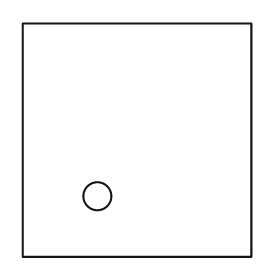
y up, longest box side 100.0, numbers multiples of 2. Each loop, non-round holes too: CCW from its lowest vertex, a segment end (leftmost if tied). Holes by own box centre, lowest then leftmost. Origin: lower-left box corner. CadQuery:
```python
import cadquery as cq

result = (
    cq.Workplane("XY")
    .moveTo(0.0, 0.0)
    .lineTo(98.0, 0.0)
    .lineTo(98.0, 100.0)
    .lineTo(0.0, 100.0)
    .close()
    .moveTo(32.0, 26.0)
    .circle(6.0)
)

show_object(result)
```